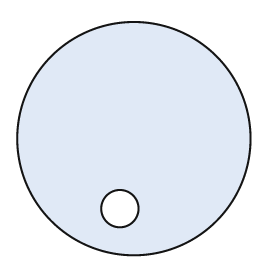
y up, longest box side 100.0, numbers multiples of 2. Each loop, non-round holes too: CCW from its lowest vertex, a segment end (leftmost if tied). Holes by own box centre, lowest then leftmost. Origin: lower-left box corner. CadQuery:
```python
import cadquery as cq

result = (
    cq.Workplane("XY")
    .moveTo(50.0, 50.0)
    .circle(50.0)
    .moveTo(44.0, 20.0)
    .circle(8.0)
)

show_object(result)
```